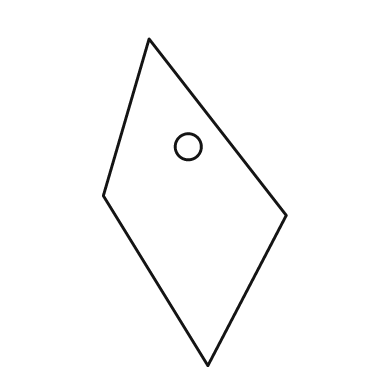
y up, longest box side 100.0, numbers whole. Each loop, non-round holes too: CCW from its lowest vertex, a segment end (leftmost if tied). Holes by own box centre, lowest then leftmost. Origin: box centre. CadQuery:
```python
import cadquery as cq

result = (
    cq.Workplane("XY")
    .moveTo(4.0, -50.0)
    .lineTo(28.0, -4.0)
    .lineTo(-14.0, 50.0)
    .lineTo(-28.0, 2.0)
    .close()
    .moveTo(-2.0, 17.0)
    .circle(4.0)
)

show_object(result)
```